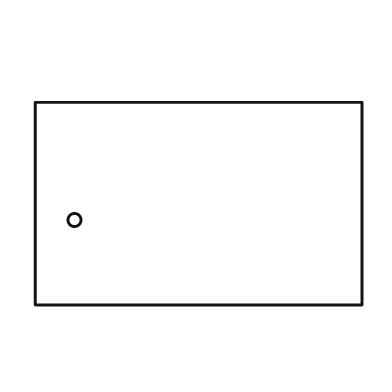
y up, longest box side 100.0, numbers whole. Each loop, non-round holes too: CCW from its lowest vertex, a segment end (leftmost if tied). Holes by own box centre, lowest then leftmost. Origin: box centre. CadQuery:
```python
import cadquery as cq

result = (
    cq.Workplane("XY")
    .moveTo(-50.0, -31.0)
    .lineTo(50.0, -31.0)
    .lineTo(50.0, 31.0)
    .lineTo(-50.0, 31.0)
    .close()
    .moveTo(-38.0, -5.0)
    .circle(2.0)
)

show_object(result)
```